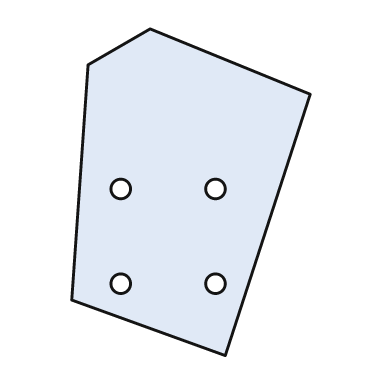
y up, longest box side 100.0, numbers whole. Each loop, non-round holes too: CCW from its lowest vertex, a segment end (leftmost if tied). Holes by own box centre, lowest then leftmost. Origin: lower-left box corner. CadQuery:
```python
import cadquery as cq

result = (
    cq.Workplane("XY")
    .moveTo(47.0, 0.0)
    .lineTo(73.0, 80.0)
    .lineTo(24.0, 100.0)
    .lineTo(5.0, 89.0)
    .lineTo(0.0, 17.0)
    .close()
    .moveTo(15.0, 22.0)
    .circle(3.0)
    .moveTo(44.0, 22.0)
    .circle(3.0)
    .moveTo(15.0, 51.0)
    .circle(3.0)
    .moveTo(44.0, 51.0)
    .circle(3.0)
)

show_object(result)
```